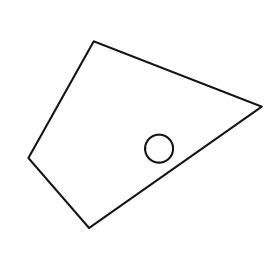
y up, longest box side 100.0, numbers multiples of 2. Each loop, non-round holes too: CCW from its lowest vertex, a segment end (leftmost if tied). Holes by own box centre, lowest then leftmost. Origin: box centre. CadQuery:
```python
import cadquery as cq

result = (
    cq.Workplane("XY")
    .moveTo(-24.0, -40.0)
    .lineTo(50.0, 12.0)
    .lineTo(-22.0, 40.0)
    .lineTo(-50.0, -10.0)
    .close()
    .moveTo(6.0, -6.0)
    .circle(6.0)
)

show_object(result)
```